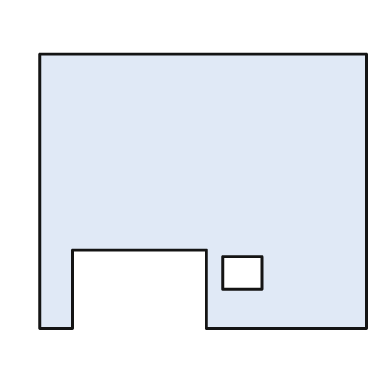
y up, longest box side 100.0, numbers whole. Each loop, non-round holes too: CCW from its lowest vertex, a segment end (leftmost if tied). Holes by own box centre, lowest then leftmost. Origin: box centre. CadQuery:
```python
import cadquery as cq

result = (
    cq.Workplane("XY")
    .moveTo(-50.0, -42.0)
    .lineTo(-40.0, -42.0)
    .lineTo(-40.0, -18.0)
    .lineTo(1.0, -18.0)
    .lineTo(1.0, -42.0)
    .lineTo(50.0, -42.0)
    .lineTo(50.0, 42.0)
    .lineTo(-50.0, 42.0)
    .close()
    .moveTo(6.0, -30.0)
    .lineTo(18.0, -30.0)
    .lineTo(18.0, -20.0)
    .lineTo(6.0, -20.0)
    .close()
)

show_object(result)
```